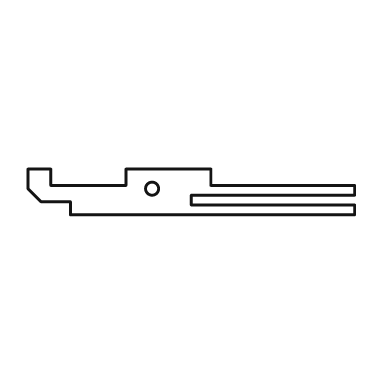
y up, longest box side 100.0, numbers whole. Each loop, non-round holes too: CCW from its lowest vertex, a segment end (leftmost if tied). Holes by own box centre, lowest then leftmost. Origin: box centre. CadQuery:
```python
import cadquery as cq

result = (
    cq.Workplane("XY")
    .moveTo(-37.0, -7.0)
    .lineTo(50.0, -7.0)
    .lineTo(50.0, -4.0)
    .lineTo(0.0, -4.0)
    .lineTo(0.0, -1.0)
    .lineTo(50.0, -1.0)
    .lineTo(50.0, 2.0)
    .lineTo(6.0, 2.0)
    .lineTo(6.0, 7.0)
    .lineTo(-20.0, 7.0)
    .lineTo(-20.0, 2.0)
    .lineTo(-43.0, 2.0)
    .lineTo(-43.0, 7.0)
    .lineTo(-50.0, 7.0)
    .lineTo(-50.0, 1.0)
    .lineTo(-46.0, -3.0)
    .lineTo(-37.0, -3.0)
    .close()
    .moveTo(-12.0, 1.0)
    .circle(2.0)
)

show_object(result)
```